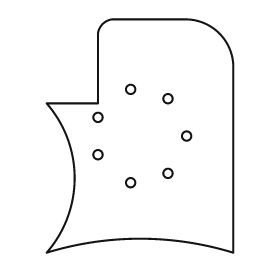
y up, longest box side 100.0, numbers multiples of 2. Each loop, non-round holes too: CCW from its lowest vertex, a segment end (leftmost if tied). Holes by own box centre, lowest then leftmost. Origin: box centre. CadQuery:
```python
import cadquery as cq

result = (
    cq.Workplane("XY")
    .moveTo(-40.0, -50.0)
    .threePointArc((0.0, -44.0), (40.0, -50.0))
    .lineTo(40.0, 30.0)
    .threePointArc((34.0, 44.0), (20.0, 50.0))
    .lineTo(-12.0, 50.0)
    .threePointArc((-16.0, 48.0), (-18.0, 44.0))
    .lineTo(-18.0, 14.0)
    .lineTo(-40.0, 14.0)
    .threePointArc((-28.0, -18.0), (-40.0, -50.0))
    .close()
    .moveTo(-4.0, -20.0)
    .circle(2.0)
    .moveTo(12.0, -16.0)
    .circle(2.0)
    .moveTo(-18.0, -8.0)
    .circle(2.0)
    .moveTo(20.0, 0.0)
    .circle(2.0)
    .moveTo(-18.0, 8.0)
    .circle(2.0)
    .moveTo(12.0, 16.0)
    .circle(2.0)
    .moveTo(-4.0, 20.0)
    .circle(2.0)
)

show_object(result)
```